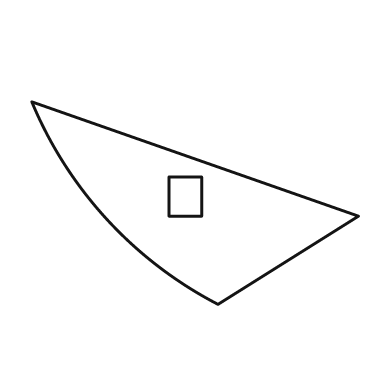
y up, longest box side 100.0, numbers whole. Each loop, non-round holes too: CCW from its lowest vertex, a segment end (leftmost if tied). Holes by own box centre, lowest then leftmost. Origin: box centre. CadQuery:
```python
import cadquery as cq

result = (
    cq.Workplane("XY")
    .moveTo(7.0, -31.0)
    .lineTo(50.0, -4.0)
    .lineTo(-50.0, 31.0)
    .threePointArc((-27.0, -5.0), (7.0, -31.0))
    .close()
    .moveTo(-8.0, -4.0)
    .lineTo(2.0, -4.0)
    .lineTo(2.0, 8.0)
    .lineTo(-8.0, 8.0)
    .close()
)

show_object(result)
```